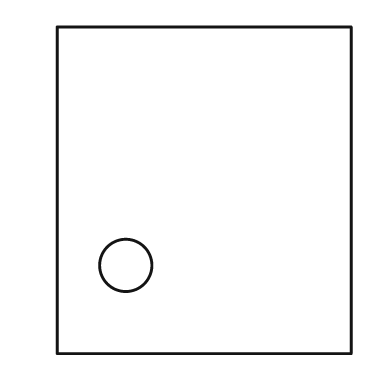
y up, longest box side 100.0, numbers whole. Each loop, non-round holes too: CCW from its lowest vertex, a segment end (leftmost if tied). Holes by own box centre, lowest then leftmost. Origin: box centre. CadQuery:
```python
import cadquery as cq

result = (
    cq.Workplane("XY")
    .moveTo(-45.0, -50.0)
    .lineTo(45.0, -50.0)
    .lineTo(45.0, 50.0)
    .lineTo(-45.0, 50.0)
    .close()
    .moveTo(-24.0, -23.0)
    .circle(8.0)
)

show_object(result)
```